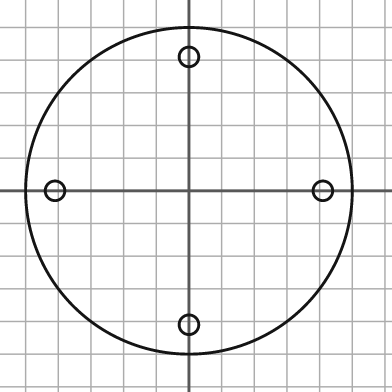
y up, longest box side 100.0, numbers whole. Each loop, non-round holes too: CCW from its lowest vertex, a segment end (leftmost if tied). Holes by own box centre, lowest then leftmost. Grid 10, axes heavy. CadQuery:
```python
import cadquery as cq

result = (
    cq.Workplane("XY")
    .moveTo(0.0, 0.0)
    .circle(50.0)
    .moveTo(0.0, -41.0)
    .circle(3.0)
    .moveTo(-41.0, 0.0)
    .circle(3.0)
    .moveTo(41.0, 0.0)
    .circle(3.0)
    .moveTo(0.0, 41.0)
    .circle(3.0)
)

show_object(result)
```